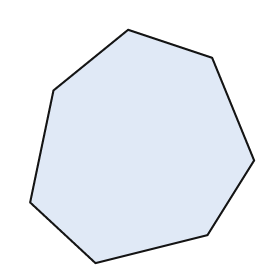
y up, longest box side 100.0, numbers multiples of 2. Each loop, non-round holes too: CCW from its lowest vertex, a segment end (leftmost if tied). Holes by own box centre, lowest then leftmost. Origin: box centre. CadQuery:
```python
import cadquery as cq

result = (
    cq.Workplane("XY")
    .moveTo(-20.0, -50.0)
    .lineTo(28.0, -38.0)
    .lineTo(48.0, -6.0)
    .lineTo(30.0, 38.0)
    .lineTo(-6.0, 50.0)
    .lineTo(-38.0, 24.0)
    .lineTo(-48.0, -24.0)
    .close()
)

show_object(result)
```